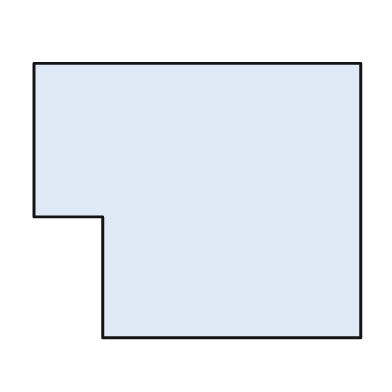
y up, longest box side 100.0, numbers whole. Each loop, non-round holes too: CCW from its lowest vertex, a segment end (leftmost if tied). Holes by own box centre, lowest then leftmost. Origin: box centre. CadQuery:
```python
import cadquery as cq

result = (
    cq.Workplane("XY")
    .moveTo(-29.0, -42.0)
    .lineTo(50.0, -42.0)
    .lineTo(50.0, 42.0)
    .lineTo(-50.0, 42.0)
    .lineTo(-50.0, -5.0)
    .lineTo(-29.0, -5.0)
    .close()
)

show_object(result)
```